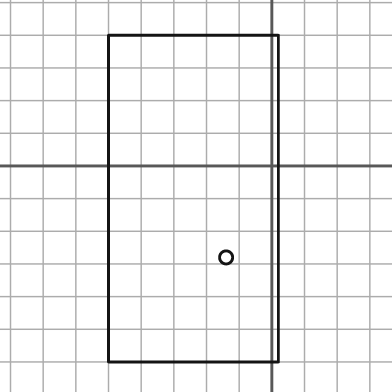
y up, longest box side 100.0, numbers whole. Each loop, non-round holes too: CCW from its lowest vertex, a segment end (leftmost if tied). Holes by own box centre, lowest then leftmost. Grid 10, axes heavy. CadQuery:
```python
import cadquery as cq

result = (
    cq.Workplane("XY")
    .moveTo(-50.0, -60.0)
    .lineTo(2.0, -60.0)
    .lineTo(2.0, 40.0)
    .lineTo(-50.0, 40.0)
    .close()
    .moveTo(-14.0, -28.0)
    .circle(2.0)
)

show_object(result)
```